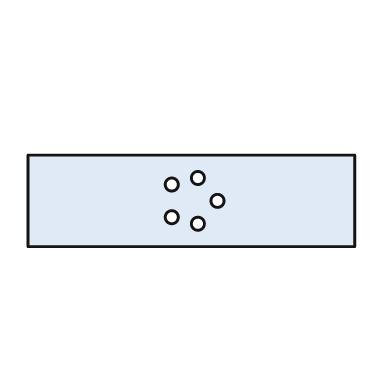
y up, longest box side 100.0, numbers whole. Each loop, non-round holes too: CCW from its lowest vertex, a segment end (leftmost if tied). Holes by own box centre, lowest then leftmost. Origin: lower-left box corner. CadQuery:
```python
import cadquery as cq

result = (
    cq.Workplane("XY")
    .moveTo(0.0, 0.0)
    .lineTo(100.0, 0.0)
    .lineTo(100.0, 28.0)
    .lineTo(0.0, 28.0)
    .close()
    .moveTo(52.0, 7.0)
    .circle(2.0)
    .moveTo(44.0, 9.0)
    .circle(2.0)
    .moveTo(58.0, 14.0)
    .circle(2.0)
    .moveTo(44.0, 19.0)
    .circle(2.0)
    .moveTo(52.0, 21.0)
    .circle(2.0)
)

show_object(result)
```